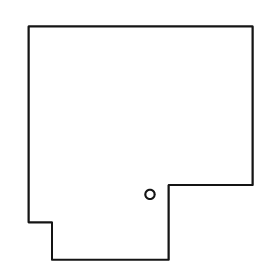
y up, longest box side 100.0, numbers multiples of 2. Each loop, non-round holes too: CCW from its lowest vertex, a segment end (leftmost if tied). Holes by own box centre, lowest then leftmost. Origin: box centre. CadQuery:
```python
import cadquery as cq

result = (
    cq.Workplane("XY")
    .moveTo(-38.0, -50.0)
    .lineTo(12.0, -50.0)
    .lineTo(12.0, -18.0)
    .lineTo(48.0, -18.0)
    .lineTo(48.0, 50.0)
    .lineTo(-48.0, 50.0)
    .lineTo(-48.0, -34.0)
    .lineTo(-38.0, -34.0)
    .close()
    .moveTo(4.0, -22.0)
    .circle(2.0)
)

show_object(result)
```